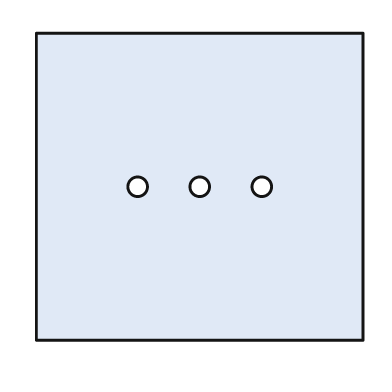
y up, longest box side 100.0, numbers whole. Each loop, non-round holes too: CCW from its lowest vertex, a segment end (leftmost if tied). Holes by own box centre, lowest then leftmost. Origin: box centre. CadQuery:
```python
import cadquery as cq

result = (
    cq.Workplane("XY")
    .moveTo(-50.0, -47.0)
    .lineTo(50.0, -47.0)
    .lineTo(50.0, 47.0)
    .lineTo(-50.0, 47.0)
    .close()
    .moveTo(-19.0, 0.0)
    .circle(3.0)
    .moveTo(0.0, 0.0)
    .circle(3.0)
    .moveTo(19.0, 0.0)
    .circle(3.0)
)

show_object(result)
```